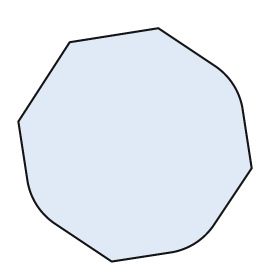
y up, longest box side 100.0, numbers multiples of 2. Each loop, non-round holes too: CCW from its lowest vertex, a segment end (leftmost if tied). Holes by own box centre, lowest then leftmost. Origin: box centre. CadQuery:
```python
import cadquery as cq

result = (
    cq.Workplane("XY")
    .moveTo(-10.0, -50.0)
    .lineTo(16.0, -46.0)
    .threePointArc((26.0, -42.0), (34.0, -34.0))
    .lineTo(50.0, -10.0)
    .lineTo(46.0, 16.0)
    .threePointArc((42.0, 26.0), (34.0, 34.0))
    .lineTo(10.0, 50.0)
    .lineTo(-28.0, 44.0)
    .lineTo(-50.0, 10.0)
    .lineTo(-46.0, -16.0)
    .threePointArc((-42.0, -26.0), (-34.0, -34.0))
    .close()
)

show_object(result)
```